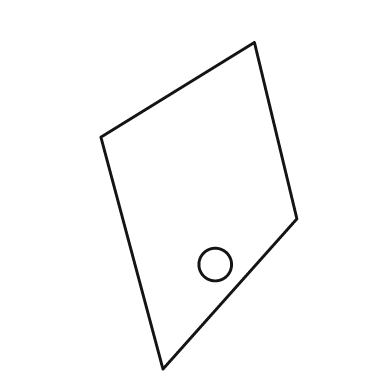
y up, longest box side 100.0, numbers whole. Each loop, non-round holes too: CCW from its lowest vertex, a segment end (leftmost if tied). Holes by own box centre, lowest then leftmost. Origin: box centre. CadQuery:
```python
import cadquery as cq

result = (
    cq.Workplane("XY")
    .moveTo(-11.0, -50.0)
    .lineTo(30.0, -4.0)
    .lineTo(17.0, 50.0)
    .lineTo(-30.0, 21.0)
    .close()
    .moveTo(5.0, -18.0)
    .circle(5.0)
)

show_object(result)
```